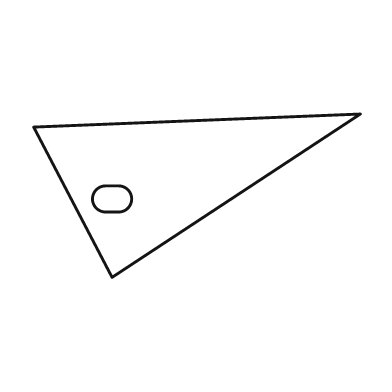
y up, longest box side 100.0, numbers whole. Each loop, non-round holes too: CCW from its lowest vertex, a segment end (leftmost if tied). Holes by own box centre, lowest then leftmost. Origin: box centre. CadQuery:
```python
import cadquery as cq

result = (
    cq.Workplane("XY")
    .moveTo(-26.0, -25.0)
    .lineTo(50.0, 25.0)
    .lineTo(-50.0, 21.0)
    .close()
    .moveTo(-28.0, -5.0)
    .lineTo(-24.0, -5.0)
    .threePointArc((-20.0, -1.0), (-24.0, 3.0))
    .lineTo(-28.0, 3.0)
    .threePointArc((-32.0, -1.0), (-28.0, -5.0))
    .close()
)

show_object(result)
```